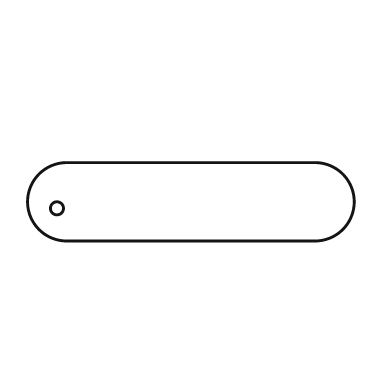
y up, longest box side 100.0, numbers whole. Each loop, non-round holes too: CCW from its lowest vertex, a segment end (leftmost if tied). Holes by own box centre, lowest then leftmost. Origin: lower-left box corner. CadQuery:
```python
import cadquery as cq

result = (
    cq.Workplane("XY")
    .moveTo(12.0, 0.0)
    .lineTo(88.0, 0.0)
    .threePointArc((100.0, 12.0), (88.0, 24.0))
    .lineTo(12.0, 24.0)
    .threePointArc((0.0, 12.0), (12.0, 0.0))
    .close()
    .moveTo(9.0, 10.0)
    .circle(2.0)
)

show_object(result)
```